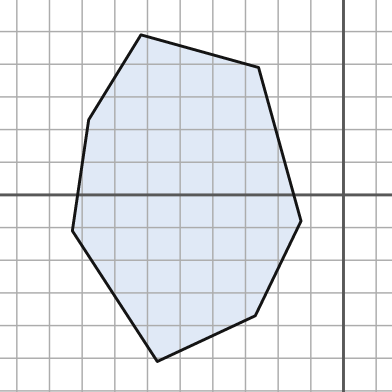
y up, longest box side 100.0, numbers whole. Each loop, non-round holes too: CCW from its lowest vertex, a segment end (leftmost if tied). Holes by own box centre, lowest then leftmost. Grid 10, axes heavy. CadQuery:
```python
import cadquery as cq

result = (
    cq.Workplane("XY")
    .moveTo(-57.0, -51.0)
    .lineTo(-27.0, -37.0)
    .lineTo(-13.0, -8.0)
    .lineTo(-26.0, 39.0)
    .lineTo(-62.0, 49.0)
    .lineTo(-78.0, 23.0)
    .lineTo(-83.0, -11.0)
    .close()
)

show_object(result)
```